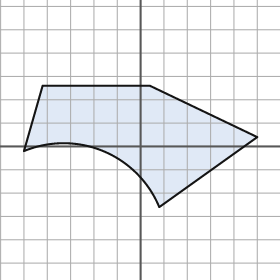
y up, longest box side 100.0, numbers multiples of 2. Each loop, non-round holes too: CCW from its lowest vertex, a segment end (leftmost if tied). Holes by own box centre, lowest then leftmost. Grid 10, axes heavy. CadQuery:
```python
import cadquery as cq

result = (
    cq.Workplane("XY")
    .moveTo(8.0, -26.0)
    .lineTo(50.0, 4.0)
    .lineTo(4.0, 26.0)
    .lineTo(-42.0, 26.0)
    .lineTo(-50.0, -2.0)
    .threePointArc((-16.0, -2.0), (8.0, -26.0))
    .close()
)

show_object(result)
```